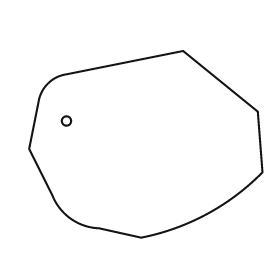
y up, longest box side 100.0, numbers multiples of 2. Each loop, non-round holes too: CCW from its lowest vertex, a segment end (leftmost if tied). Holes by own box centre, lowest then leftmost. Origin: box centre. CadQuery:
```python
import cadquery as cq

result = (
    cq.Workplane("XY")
    .moveTo(-2.0, -40.0)
    .threePointArc((26.0, -30.0), (50.0, -12.0))
    .lineTo(48.0, 14.0)
    .lineTo(16.0, 40.0)
    .lineTo(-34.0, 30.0)
    .threePointArc((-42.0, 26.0), (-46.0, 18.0))
    .lineTo(-50.0, -2.0)
    .lineTo(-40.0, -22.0)
    .threePointArc((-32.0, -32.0), (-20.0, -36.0))
    .close()
    .moveTo(-34.0, 10.0)
    .circle(2.0)
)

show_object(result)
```